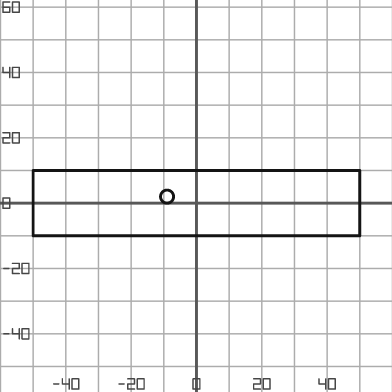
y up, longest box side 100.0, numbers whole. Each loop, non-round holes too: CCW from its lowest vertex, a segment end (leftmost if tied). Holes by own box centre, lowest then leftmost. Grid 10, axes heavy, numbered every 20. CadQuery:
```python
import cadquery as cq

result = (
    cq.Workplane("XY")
    .moveTo(-50.0, -10.0)
    .lineTo(50.0, -10.0)
    .lineTo(50.0, 10.0)
    .lineTo(-50.0, 10.0)
    .close()
    .moveTo(-9.0, 2.0)
    .circle(2.0)
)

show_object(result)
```